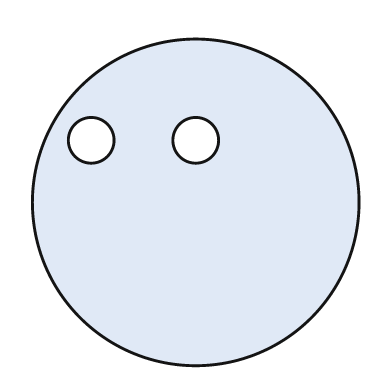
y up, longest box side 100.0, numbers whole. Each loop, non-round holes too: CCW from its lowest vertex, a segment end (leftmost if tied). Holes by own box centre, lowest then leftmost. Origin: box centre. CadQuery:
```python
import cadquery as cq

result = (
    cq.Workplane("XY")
    .moveTo(0.0, 0.0)
    .circle(50.0)
    .moveTo(-32.0, 19.0)
    .circle(7.0)
    .moveTo(0.0, 19.0)
    .circle(7.0)
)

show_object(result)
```